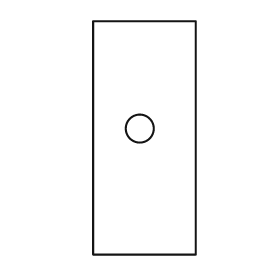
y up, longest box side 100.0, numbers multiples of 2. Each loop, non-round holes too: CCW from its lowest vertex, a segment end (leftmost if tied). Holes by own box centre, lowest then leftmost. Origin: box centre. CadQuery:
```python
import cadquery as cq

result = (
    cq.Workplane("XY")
    .moveTo(-22.0, -50.0)
    .lineTo(22.0, -50.0)
    .lineTo(22.0, 50.0)
    .lineTo(-22.0, 50.0)
    .close()
    .moveTo(-2.0, 4.0)
    .circle(6.0)
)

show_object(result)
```